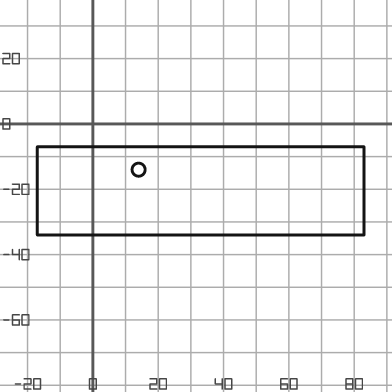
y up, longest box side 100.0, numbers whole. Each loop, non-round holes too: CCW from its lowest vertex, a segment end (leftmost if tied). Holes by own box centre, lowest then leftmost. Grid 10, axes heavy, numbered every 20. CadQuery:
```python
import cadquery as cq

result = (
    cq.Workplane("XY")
    .moveTo(-17.0, -34.0)
    .lineTo(83.0, -34.0)
    .lineTo(83.0, -7.0)
    .lineTo(-17.0, -7.0)
    .close()
    .moveTo(14.0, -14.0)
    .circle(2.0)
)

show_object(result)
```